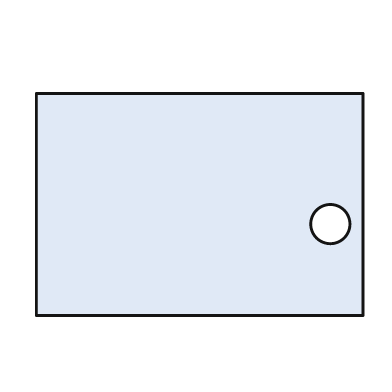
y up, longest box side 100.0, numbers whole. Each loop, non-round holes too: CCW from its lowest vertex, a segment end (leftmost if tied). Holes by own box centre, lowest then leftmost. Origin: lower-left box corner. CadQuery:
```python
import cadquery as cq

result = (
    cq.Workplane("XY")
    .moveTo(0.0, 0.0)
    .lineTo(100.0, 0.0)
    .lineTo(100.0, 68.0)
    .lineTo(0.0, 68.0)
    .close()
    .moveTo(90.0, 28.0)
    .circle(6.0)
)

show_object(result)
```